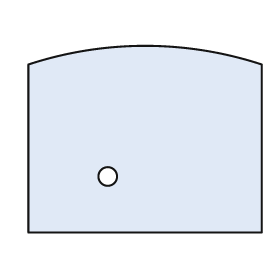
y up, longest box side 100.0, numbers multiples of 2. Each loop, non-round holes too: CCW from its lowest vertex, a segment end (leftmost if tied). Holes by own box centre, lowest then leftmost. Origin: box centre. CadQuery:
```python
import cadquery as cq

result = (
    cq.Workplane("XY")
    .moveTo(-50.0, -40.0)
    .lineTo(50.0, -40.0)
    .lineTo(50.0, 32.0)
    .threePointArc((0.0, 40.0), (-50.0, 32.0))
    .close()
    .moveTo(-16.0, -16.0)
    .circle(4.0)
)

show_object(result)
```